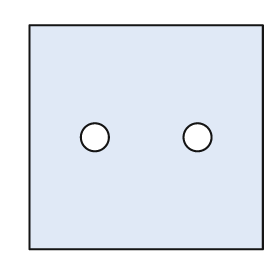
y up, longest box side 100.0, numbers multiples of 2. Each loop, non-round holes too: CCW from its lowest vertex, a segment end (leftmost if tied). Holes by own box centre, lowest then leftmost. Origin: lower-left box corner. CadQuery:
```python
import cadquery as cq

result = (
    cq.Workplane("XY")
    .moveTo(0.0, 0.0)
    .lineTo(100.0, 0.0)
    .lineTo(100.0, 96.0)
    .lineTo(0.0, 96.0)
    .close()
    .moveTo(28.0, 48.0)
    .circle(6.0)
    .moveTo(72.0, 48.0)
    .circle(6.0)
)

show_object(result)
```